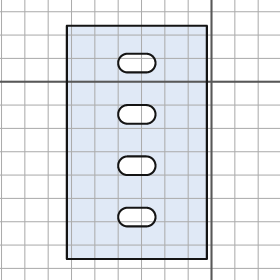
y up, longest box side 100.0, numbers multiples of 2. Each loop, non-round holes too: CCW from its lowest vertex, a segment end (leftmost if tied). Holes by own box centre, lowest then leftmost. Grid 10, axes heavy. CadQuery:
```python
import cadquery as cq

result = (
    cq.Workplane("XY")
    .moveTo(-62.0, -76.0)
    .lineTo(-2.0, -76.0)
    .lineTo(-2.0, 24.0)
    .lineTo(-62.0, 24.0)
    .close()
    .moveTo(-36.0, -62.0)
    .lineTo(-28.0, -62.0)
    .threePointArc((-24.0, -58.0), (-28.0, -54.0))
    .lineTo(-36.0, -54.0)
    .threePointArc((-40.0, -58.0), (-36.0, -62.0))
    .close()
    .moveTo(-36.0, -40.0)
    .lineTo(-28.0, -40.0)
    .threePointArc((-24.0, -36.0), (-28.0, -32.0))
    .lineTo(-36.0, -32.0)
    .threePointArc((-40.0, -36.0), (-36.0, -40.0))
    .close()
    .moveTo(-36.0, -18.0)
    .lineTo(-28.0, -18.0)
    .threePointArc((-24.0, -14.0), (-28.0, -10.0))
    .lineTo(-36.0, -10.0)
    .threePointArc((-40.0, -14.0), (-36.0, -18.0))
    .close()
    .moveTo(-36.0, 4.0)
    .lineTo(-28.0, 4.0)
    .threePointArc((-24.0, 8.0), (-28.0, 12.0))
    .lineTo(-36.0, 12.0)
    .threePointArc((-40.0, 8.0), (-36.0, 4.0))
    .close()
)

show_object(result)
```